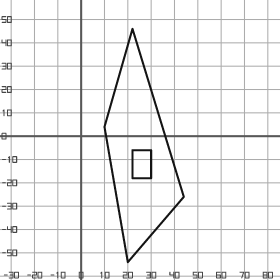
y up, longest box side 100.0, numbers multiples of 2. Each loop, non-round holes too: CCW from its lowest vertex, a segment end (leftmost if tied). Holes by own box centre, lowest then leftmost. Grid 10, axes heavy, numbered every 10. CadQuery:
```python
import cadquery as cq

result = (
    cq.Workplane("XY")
    .moveTo(20.0, -54.0)
    .lineTo(44.0, -26.0)
    .lineTo(22.0, 46.0)
    .lineTo(10.0, 4.0)
    .close()
    .moveTo(22.0, -18.0)
    .lineTo(30.0, -18.0)
    .lineTo(30.0, -6.0)
    .lineTo(22.0, -6.0)
    .close()
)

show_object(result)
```